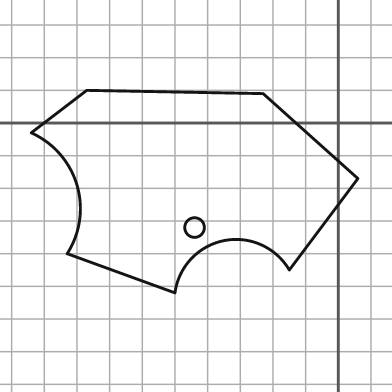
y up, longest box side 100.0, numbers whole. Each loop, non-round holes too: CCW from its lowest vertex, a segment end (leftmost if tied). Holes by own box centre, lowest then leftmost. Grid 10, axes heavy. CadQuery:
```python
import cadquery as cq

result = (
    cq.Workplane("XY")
    .moveTo(-50.0, -52.0)
    .threePointArc((-35.0, -36.0), (-15.0, -45.0))
    .lineTo(6.0, -17.0)
    .lineTo(-23.0, 9.0)
    .lineTo(-77.0, 10.0)
    .lineTo(-94.0, -3.0)
    .threePointArc((-80.0, -19.0), (-83.0, -40.0))
    .close()
    .moveTo(-44.0, -32.0)
    .circle(3.0)
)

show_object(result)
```